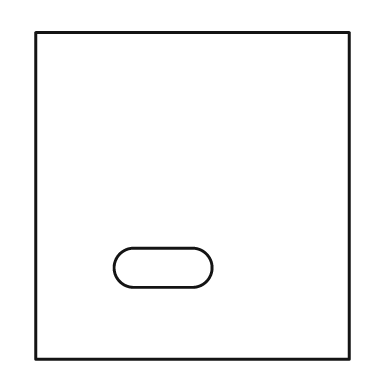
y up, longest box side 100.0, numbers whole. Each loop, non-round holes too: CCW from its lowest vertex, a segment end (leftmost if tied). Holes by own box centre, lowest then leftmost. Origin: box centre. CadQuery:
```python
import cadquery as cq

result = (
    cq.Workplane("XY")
    .moveTo(-48.0, -50.0)
    .lineTo(48.0, -50.0)
    .lineTo(48.0, 50.0)
    .lineTo(-48.0, 50.0)
    .close()
    .moveTo(-18.0, -28.0)
    .lineTo(0.0, -28.0)
    .threePointArc((6.0, -22.0), (0.0, -16.0))
    .lineTo(-18.0, -16.0)
    .threePointArc((-24.0, -22.0), (-18.0, -28.0))
    .close()
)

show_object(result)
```